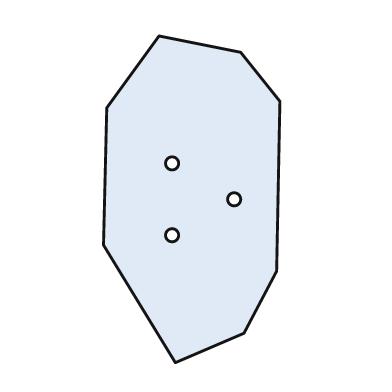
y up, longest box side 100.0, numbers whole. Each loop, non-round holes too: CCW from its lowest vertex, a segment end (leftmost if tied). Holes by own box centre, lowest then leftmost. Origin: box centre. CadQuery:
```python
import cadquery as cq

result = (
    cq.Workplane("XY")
    .moveTo(-5.0, -50.0)
    .lineTo(16.0, -41.0)
    .lineTo(26.0, -22.0)
    .lineTo(27.0, 30.0)
    .lineTo(15.0, 45.0)
    .lineTo(-10.0, 50.0)
    .lineTo(-26.0, 28.0)
    .lineTo(-27.0, -14.0)
    .close()
    .moveTo(-6.0, -11.0)
    .circle(2.0)
    .moveTo(13.0, 0.0)
    .circle(2.0)
    .moveTo(-6.0, 11.0)
    .circle(2.0)
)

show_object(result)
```